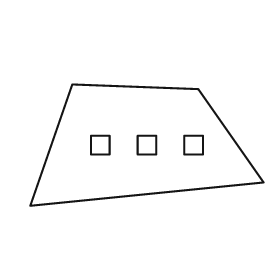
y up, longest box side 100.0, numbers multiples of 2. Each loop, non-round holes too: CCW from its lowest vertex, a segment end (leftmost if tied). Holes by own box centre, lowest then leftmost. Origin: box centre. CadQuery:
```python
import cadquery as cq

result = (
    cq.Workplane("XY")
    .moveTo(-50.0, -26.0)
    .lineTo(50.0, -16.0)
    .lineTo(22.0, 24.0)
    .lineTo(-32.0, 26.0)
    .close()
    .moveTo(-24.0, -4.0)
    .lineTo(-16.0, -4.0)
    .lineTo(-16.0, 4.0)
    .lineTo(-24.0, 4.0)
    .close()
    .moveTo(-4.0, -4.0)
    .lineTo(4.0, -4.0)
    .lineTo(4.0, 4.0)
    .lineTo(-4.0, 4.0)
    .close()
    .moveTo(16.0, -4.0)
    .lineTo(24.0, -4.0)
    .lineTo(24.0, 4.0)
    .lineTo(16.0, 4.0)
    .close()
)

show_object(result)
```